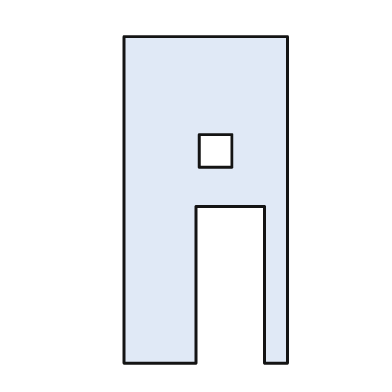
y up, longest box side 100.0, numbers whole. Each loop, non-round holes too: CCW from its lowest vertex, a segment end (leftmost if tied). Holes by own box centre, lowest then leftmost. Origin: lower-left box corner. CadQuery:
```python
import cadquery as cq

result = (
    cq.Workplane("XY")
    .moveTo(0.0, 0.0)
    .lineTo(22.0, 0.0)
    .lineTo(22.0, 48.0)
    .lineTo(43.0, 48.0)
    .lineTo(43.0, 0.0)
    .lineTo(50.0, 0.0)
    .lineTo(50.0, 100.0)
    .lineTo(0.0, 100.0)
    .close()
    .moveTo(23.0, 60.0)
    .lineTo(33.0, 60.0)
    .lineTo(33.0, 70.0)
    .lineTo(23.0, 70.0)
    .close()
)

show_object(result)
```